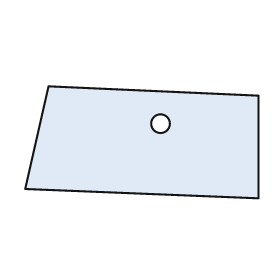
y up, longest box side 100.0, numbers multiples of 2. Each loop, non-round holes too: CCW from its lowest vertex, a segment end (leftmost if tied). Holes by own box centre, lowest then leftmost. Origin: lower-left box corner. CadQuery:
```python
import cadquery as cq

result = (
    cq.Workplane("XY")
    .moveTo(100.0, 0.0)
    .lineTo(100.0, 44.0)
    .lineTo(10.0, 48.0)
    .lineTo(0.0, 4.0)
    .close()
    .moveTo(58.0, 32.0)
    .circle(4.0)
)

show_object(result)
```